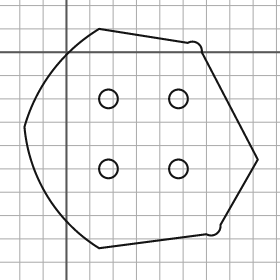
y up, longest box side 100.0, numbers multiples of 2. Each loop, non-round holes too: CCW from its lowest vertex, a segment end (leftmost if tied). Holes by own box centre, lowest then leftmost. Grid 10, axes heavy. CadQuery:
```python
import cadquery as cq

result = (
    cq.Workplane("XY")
    .moveTo(14.0, -84.0)
    .lineTo(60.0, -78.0)
    .threePointArc((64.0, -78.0), (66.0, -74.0))
    .lineTo(82.0, -46.0)
    .lineTo(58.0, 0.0)
    .threePointArc((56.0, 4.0), (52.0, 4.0))
    .lineTo(14.0, 10.0)
    .threePointArc((-6.0, -8.0), (-18.0, -32.0))
    .threePointArc((-8.0, -62.0), (14.0, -84.0))
    .close()
    .moveTo(18.0, -50.0)
    .circle(4.0)
    .moveTo(48.0, -50.0)
    .circle(4.0)
    .moveTo(18.0, -20.0)
    .circle(4.0)
    .moveTo(48.0, -20.0)
    .circle(4.0)
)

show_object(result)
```